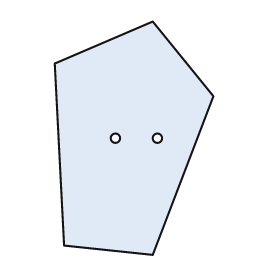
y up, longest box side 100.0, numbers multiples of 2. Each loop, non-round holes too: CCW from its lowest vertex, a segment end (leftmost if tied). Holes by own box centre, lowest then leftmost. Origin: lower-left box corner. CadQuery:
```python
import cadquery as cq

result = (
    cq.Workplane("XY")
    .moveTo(42.0, 0.0)
    .lineTo(68.0, 68.0)
    .lineTo(42.0, 100.0)
    .lineTo(0.0, 82.0)
    .lineTo(4.0, 4.0)
    .close()
    .moveTo(26.0, 50.0)
    .circle(2.0)
    .moveTo(44.0, 50.0)
    .circle(2.0)
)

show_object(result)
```